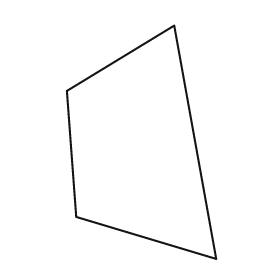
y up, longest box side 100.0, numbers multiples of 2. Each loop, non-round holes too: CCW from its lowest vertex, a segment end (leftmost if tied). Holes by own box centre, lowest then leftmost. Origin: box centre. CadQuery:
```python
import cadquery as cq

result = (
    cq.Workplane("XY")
    .moveTo(32.0, -50.0)
    .lineTo(14.0, 50.0)
    .lineTo(-32.0, 22.0)
    .lineTo(-28.0, -32.0)
    .close()
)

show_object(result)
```